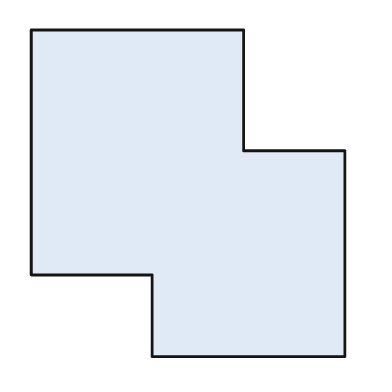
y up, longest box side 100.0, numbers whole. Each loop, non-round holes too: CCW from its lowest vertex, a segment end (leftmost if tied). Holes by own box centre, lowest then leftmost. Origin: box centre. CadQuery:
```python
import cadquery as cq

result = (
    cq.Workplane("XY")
    .moveTo(-11.0, -50.0)
    .lineTo(48.0, -50.0)
    .lineTo(48.0, 13.0)
    .lineTo(17.0, 13.0)
    .lineTo(17.0, 50.0)
    .lineTo(-48.0, 50.0)
    .lineTo(-48.0, -25.0)
    .lineTo(-11.0, -25.0)
    .close()
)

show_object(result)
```